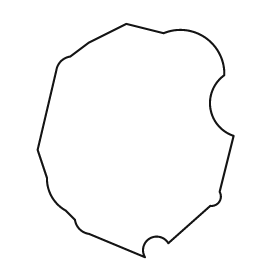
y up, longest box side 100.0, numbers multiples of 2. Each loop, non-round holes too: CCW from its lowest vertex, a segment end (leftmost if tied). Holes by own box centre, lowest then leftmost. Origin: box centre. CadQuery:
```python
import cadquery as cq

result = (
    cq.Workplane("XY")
    .moveTo(4.0, -50.0)
    .threePointArc((6.0, -42.0), (14.0, -44.0))
    .lineTo(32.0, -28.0)
    .threePointArc((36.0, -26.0), (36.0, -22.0))
    .lineTo(42.0, 2.0)
    .threePointArc((32.0, 14.0), (38.0, 28.0))
    .threePointArc((30.0, 44.0), (12.0, 46.0))
    .lineTo(-4.0, 50.0)
    .lineTo(-20.0, 42.0)
    .lineTo(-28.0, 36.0)
    .threePointArc((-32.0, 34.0), (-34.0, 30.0))
    .lineTo(-42.0, -4.0)
    .lineTo(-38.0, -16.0)
    .threePointArc((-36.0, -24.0), (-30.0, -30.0))
    .lineTo(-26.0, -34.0)
    .threePointArc((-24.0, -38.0), (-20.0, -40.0))
    .close()
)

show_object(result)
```